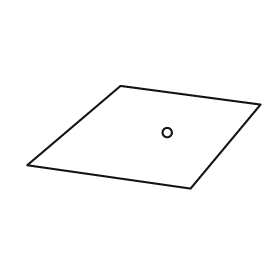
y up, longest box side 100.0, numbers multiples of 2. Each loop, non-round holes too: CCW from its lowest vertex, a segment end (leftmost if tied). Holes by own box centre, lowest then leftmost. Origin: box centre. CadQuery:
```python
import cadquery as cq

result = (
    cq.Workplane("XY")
    .moveTo(20.0, -22.0)
    .lineTo(50.0, 14.0)
    .lineTo(-10.0, 22.0)
    .lineTo(-50.0, -12.0)
    .close()
    .moveTo(10.0, 2.0)
    .circle(2.0)
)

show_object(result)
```